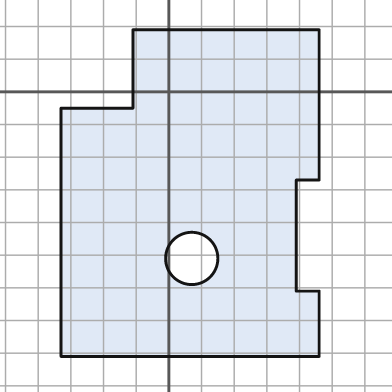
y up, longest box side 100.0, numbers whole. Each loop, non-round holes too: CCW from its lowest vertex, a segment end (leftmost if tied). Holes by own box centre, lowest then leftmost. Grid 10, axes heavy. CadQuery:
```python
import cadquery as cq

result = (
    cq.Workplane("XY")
    .moveTo(-33.0, -81.0)
    .lineTo(46.0, -81.0)
    .lineTo(46.0, -61.0)
    .lineTo(39.0, -61.0)
    .lineTo(39.0, -27.0)
    .lineTo(46.0, -27.0)
    .lineTo(46.0, 19.0)
    .lineTo(-11.0, 19.0)
    .lineTo(-11.0, -5.0)
    .lineTo(-33.0, -5.0)
    .close()
    .moveTo(7.0, -51.0)
    .circle(8.0)
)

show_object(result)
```